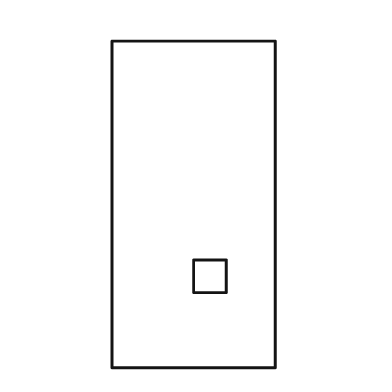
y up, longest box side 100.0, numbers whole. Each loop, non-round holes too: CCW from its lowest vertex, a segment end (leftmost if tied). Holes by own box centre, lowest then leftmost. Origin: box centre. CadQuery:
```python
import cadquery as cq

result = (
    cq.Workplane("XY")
    .moveTo(-25.0, -50.0)
    .lineTo(25.0, -50.0)
    .lineTo(25.0, 50.0)
    .lineTo(-25.0, 50.0)
    .close()
    .moveTo(0.0, -27.0)
    .lineTo(10.0, -27.0)
    .lineTo(10.0, -17.0)
    .lineTo(0.0, -17.0)
    .close()
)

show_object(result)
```